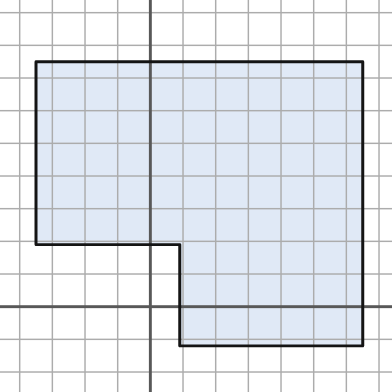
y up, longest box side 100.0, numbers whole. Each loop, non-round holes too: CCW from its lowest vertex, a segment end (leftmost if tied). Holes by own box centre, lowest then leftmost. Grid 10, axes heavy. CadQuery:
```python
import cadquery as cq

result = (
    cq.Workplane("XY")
    .moveTo(9.0, -12.0)
    .lineTo(65.0, -12.0)
    .lineTo(65.0, 75.0)
    .lineTo(-35.0, 75.0)
    .lineTo(-35.0, 19.0)
    .lineTo(9.0, 19.0)
    .close()
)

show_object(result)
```